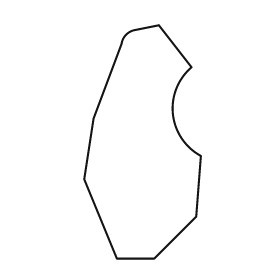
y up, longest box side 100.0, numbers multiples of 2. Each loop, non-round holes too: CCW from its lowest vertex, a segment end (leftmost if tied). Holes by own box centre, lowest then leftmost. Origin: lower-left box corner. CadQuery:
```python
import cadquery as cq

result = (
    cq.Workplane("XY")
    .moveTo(14.0, 0.0)
    .lineTo(30.0, 0.0)
    .lineTo(48.0, 18.0)
    .lineTo(50.0, 44.0)
    .threePointArc((38.0, 62.0), (46.0, 82.0))
    .lineTo(32.0, 100.0)
    .lineTo(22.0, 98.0)
    .threePointArc((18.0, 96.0), (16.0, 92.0))
    .lineTo(4.0, 60.0)
    .lineTo(0.0, 34.0)
    .close()
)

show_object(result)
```